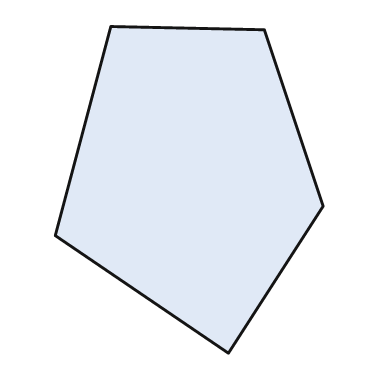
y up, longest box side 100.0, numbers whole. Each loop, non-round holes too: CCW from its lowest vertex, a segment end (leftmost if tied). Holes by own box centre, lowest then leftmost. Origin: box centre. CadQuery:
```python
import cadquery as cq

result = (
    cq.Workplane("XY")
    .moveTo(12.0, -50.0)
    .lineTo(41.0, -5.0)
    .lineTo(23.0, 49.0)
    .lineTo(-24.0, 50.0)
    .lineTo(-41.0, -14.0)
    .close()
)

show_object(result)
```